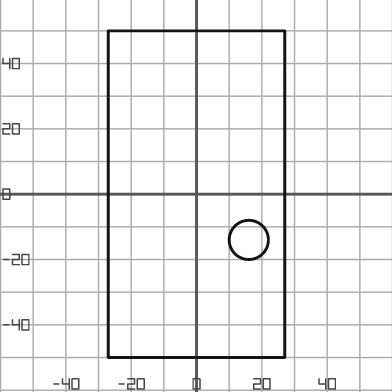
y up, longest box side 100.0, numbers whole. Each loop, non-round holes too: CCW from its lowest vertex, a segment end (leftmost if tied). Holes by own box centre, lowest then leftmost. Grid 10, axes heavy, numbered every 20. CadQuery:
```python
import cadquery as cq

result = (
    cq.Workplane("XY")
    .moveTo(-27.0, -50.0)
    .lineTo(27.0, -50.0)
    .lineTo(27.0, 50.0)
    .lineTo(-27.0, 50.0)
    .close()
    .moveTo(16.0, -14.0)
    .circle(6.0)
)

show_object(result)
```